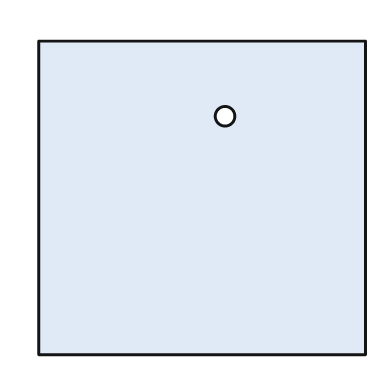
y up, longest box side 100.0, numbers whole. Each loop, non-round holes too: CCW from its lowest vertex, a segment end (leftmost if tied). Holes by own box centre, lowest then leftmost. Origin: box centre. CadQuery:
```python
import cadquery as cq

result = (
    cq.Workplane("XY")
    .moveTo(-50.0, -48.0)
    .lineTo(50.0, -48.0)
    .lineTo(50.0, 48.0)
    .lineTo(-50.0, 48.0)
    .close()
    .moveTo(7.0, 25.0)
    .circle(3.0)
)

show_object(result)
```